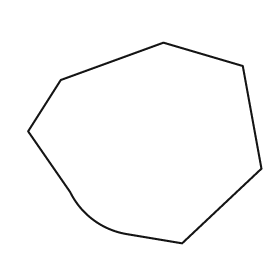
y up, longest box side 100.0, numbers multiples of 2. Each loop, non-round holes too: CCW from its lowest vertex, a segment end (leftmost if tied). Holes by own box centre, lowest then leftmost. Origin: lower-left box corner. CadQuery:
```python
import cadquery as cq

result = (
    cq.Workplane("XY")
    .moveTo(66.0, 0.0)
    .lineTo(100.0, 32.0)
    .lineTo(92.0, 76.0)
    .lineTo(58.0, 86.0)
    .lineTo(14.0, 70.0)
    .lineTo(0.0, 48.0)
    .lineTo(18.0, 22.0)
    .threePointArc((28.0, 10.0), (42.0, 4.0))
    .close()
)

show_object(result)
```